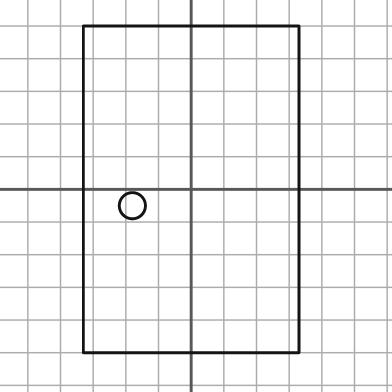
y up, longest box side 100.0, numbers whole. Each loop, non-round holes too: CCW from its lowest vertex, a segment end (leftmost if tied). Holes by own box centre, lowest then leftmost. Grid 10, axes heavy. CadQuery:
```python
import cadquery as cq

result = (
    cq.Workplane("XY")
    .moveTo(-33.0, -50.0)
    .lineTo(33.0, -50.0)
    .lineTo(33.0, 50.0)
    .lineTo(-33.0, 50.0)
    .close()
    .moveTo(-18.0, -5.0)
    .circle(4.0)
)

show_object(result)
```